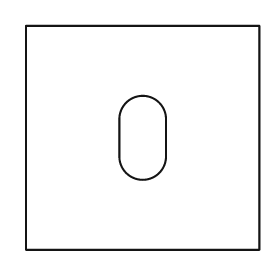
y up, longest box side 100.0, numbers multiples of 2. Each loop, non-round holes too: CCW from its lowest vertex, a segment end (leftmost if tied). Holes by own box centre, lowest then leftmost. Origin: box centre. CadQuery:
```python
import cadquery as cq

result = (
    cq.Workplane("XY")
    .moveTo(-50.0, -48.0)
    .lineTo(50.0, -48.0)
    .lineTo(50.0, 48.0)
    .lineTo(-50.0, 48.0)
    .close()
    .moveTo(-10.0, -8.0)
    .threePointArc((0.0, -18.0), (10.0, -8.0))
    .lineTo(10.0, 8.0)
    .threePointArc((0.0, 18.0), (-10.0, 8.0))
    .close()
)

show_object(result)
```